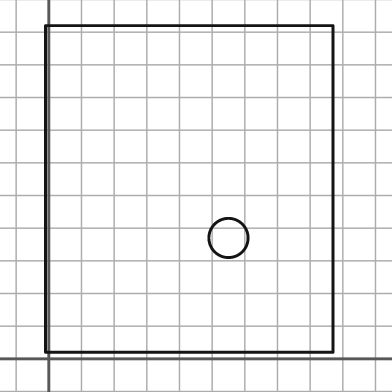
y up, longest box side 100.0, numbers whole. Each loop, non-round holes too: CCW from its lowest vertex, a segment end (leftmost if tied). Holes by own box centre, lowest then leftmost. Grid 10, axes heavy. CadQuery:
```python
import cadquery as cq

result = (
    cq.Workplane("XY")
    .moveTo(-1.0, 2.0)
    .lineTo(87.0, 2.0)
    .lineTo(87.0, 102.0)
    .lineTo(-1.0, 102.0)
    .close()
    .moveTo(55.0, 37.0)
    .circle(6.0)
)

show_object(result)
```